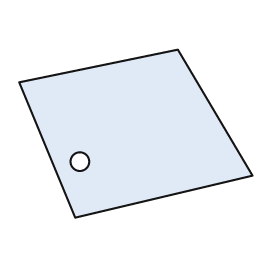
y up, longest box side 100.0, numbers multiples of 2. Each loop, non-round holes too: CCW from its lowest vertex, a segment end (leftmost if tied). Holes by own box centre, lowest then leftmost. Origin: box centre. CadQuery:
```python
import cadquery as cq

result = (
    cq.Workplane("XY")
    .moveTo(-26.0, -36.0)
    .lineTo(50.0, -18.0)
    .lineTo(18.0, 36.0)
    .lineTo(-50.0, 22.0)
    .close()
    .moveTo(-24.0, -12.0)
    .circle(4.0)
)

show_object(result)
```